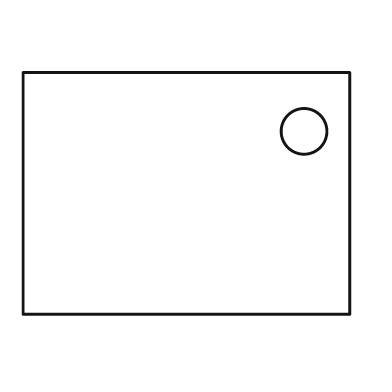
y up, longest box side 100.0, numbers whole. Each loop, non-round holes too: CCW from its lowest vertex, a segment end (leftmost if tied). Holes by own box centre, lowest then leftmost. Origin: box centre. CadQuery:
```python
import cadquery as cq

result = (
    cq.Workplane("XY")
    .moveTo(-50.0, -37.0)
    .lineTo(50.0, -37.0)
    .lineTo(50.0, 37.0)
    .lineTo(-50.0, 37.0)
    .close()
    .moveTo(36.0, 19.0)
    .circle(7.0)
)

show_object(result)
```